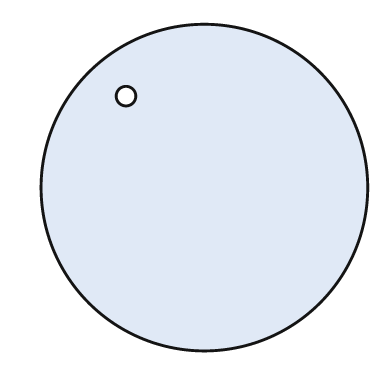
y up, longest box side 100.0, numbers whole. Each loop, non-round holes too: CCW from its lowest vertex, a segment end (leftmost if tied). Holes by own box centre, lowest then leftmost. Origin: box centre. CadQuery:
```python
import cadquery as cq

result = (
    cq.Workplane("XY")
    .moveTo(0.0, 0.0)
    .circle(50.0)
    .moveTo(-24.0, 28.0)
    .circle(3.0)
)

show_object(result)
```